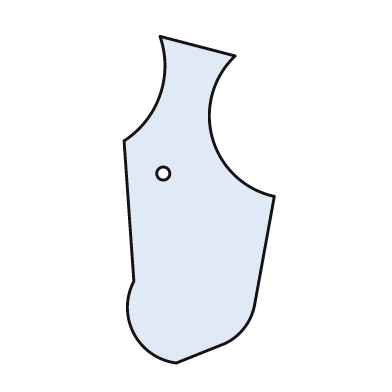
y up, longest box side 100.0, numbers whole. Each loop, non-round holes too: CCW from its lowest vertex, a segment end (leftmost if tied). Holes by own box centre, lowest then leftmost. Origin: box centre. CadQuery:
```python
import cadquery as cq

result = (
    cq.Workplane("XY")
    .moveTo(-7.0, -50.0)
    .lineTo(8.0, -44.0)
    .threePointArc((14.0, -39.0), (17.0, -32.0))
    .lineTo(23.0, 1.0)
    .threePointArc((4.0, 19.0), (11.0, 44.0))
    .lineTo(-12.0, 50.0)
    .threePointArc((-12.0, 32.0), (-23.0, 18.0))
    .lineTo(-20.0, -25.0)
    .threePointArc((-20.0, -41.0), (-7.0, -50.0))
    .close()
    .moveTo(-11.0, 8.0)
    .circle(2.0)
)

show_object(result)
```